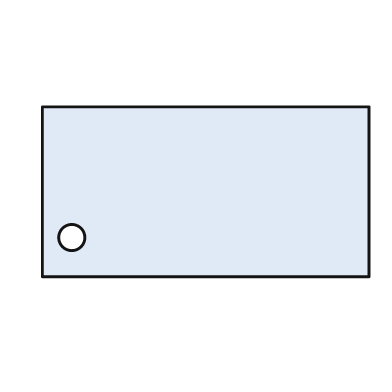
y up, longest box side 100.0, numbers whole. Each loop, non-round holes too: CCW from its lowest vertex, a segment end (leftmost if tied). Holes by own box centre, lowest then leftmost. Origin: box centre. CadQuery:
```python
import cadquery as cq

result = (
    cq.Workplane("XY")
    .moveTo(-50.0, -26.0)
    .lineTo(50.0, -26.0)
    .lineTo(50.0, 26.0)
    .lineTo(-50.0, 26.0)
    .close()
    .moveTo(-41.0, -14.0)
    .circle(4.0)
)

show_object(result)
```